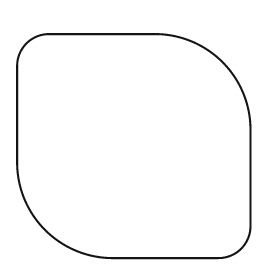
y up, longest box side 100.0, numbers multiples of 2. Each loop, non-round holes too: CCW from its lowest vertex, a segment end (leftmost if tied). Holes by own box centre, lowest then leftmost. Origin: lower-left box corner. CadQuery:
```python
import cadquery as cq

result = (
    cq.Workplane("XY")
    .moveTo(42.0, 0.0)
    .lineTo(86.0, 0.0)
    .threePointArc((96.0, 4.0), (100.0, 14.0))
    .lineTo(100.0, 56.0)
    .threePointArc((88.0, 84.0), (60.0, 96.0))
    .lineTo(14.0, 96.0)
    .threePointArc((4.0, 92.0), (0.0, 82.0))
    .lineTo(0.0, 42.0)
    .threePointArc((12.0, 12.0), (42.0, 0.0))
    .close()
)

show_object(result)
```